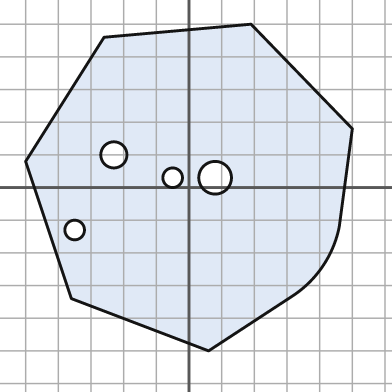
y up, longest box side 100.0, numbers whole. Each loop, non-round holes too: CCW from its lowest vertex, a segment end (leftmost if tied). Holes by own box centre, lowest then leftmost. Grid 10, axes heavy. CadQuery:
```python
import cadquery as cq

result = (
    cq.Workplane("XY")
    .moveTo(6.0, -50.0)
    .lineTo(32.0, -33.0)
    .threePointArc((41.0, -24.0), (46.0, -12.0))
    .lineTo(50.0, 18.0)
    .lineTo(19.0, 50.0)
    .lineTo(-26.0, 46.0)
    .lineTo(-50.0, 8.0)
    .lineTo(-36.0, -34.0)
    .close()
    .moveTo(-35.0, -13.0)
    .circle(3.0)
    .moveTo(-5.0, 3.0)
    .circle(3.0)
    .moveTo(8.0, 3.0)
    .circle(5.0)
    .moveTo(-23.0, 10.0)
    .circle(4.0)
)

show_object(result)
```